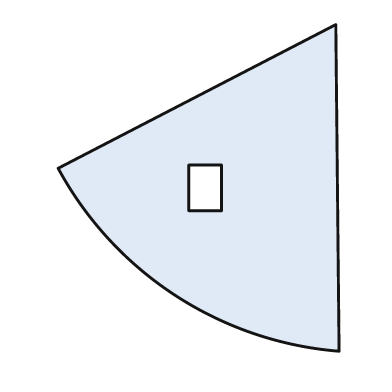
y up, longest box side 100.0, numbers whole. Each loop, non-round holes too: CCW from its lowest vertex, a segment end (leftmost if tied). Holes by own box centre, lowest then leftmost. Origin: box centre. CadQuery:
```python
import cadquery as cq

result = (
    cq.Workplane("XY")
    .moveTo(43.0, -50.0)
    .lineTo(42.0, 50.0)
    .lineTo(-43.0, 6.0)
    .threePointArc((-7.0, -33.0), (43.0, -50.0))
    .close()
    .moveTo(-3.0, -7.0)
    .lineTo(7.0, -7.0)
    .lineTo(7.0, 7.0)
    .lineTo(-3.0, 7.0)
    .close()
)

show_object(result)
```